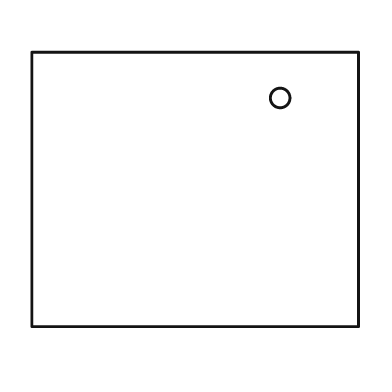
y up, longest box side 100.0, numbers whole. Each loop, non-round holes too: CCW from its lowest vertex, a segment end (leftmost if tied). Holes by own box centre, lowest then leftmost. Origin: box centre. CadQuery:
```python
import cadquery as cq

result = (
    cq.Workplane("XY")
    .moveTo(-50.0, -42.0)
    .lineTo(50.0, -42.0)
    .lineTo(50.0, 42.0)
    .lineTo(-50.0, 42.0)
    .close()
    .moveTo(26.0, 28.0)
    .circle(3.0)
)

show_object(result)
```